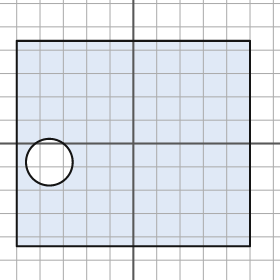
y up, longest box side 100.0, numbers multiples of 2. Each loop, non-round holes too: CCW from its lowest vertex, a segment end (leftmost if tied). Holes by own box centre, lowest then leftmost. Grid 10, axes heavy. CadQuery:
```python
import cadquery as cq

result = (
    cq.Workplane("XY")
    .moveTo(-50.0, -44.0)
    .lineTo(50.0, -44.0)
    .lineTo(50.0, 44.0)
    .lineTo(-50.0, 44.0)
    .close()
    .moveTo(-36.0, -8.0)
    .circle(10.0)
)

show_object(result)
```